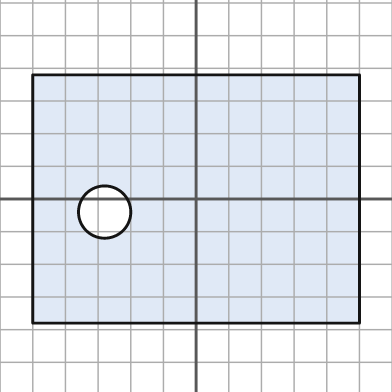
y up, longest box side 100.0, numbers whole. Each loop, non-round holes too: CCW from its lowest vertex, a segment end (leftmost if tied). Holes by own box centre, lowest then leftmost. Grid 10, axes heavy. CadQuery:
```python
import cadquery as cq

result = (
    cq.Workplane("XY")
    .moveTo(-50.0, -38.0)
    .lineTo(50.0, -38.0)
    .lineTo(50.0, 38.0)
    .lineTo(-50.0, 38.0)
    .close()
    .moveTo(-28.0, -4.0)
    .circle(8.0)
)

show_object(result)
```